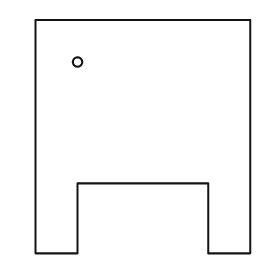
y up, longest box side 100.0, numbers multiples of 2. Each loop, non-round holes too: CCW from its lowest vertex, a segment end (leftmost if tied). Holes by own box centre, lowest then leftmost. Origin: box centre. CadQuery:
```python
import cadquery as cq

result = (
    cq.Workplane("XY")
    .moveTo(-46.0, -50.0)
    .lineTo(-28.0, -50.0)
    .lineTo(-28.0, -20.0)
    .lineTo(28.0, -20.0)
    .lineTo(28.0, -50.0)
    .lineTo(46.0, -50.0)
    .lineTo(46.0, 50.0)
    .lineTo(-46.0, 50.0)
    .close()
    .moveTo(-28.0, 32.0)
    .circle(2.0)
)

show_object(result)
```